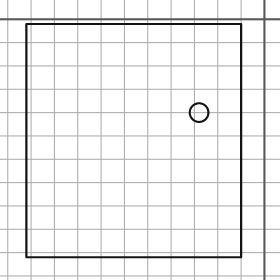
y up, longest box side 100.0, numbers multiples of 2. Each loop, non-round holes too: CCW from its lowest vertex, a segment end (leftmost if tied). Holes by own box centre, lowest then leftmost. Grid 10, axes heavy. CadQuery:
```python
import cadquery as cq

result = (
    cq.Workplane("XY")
    .moveTo(-102.0, -102.0)
    .lineTo(-10.0, -102.0)
    .lineTo(-10.0, -2.0)
    .lineTo(-102.0, -2.0)
    .close()
    .moveTo(-28.0, -40.0)
    .circle(4.0)
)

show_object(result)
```